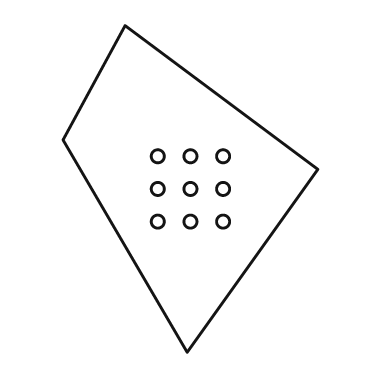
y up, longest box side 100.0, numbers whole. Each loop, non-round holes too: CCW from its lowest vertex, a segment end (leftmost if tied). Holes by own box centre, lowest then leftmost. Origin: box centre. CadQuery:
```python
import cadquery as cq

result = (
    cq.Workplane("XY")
    .moveTo(-1.0, -50.0)
    .lineTo(39.0, 6.0)
    .lineTo(-20.0, 50.0)
    .lineTo(-39.0, 15.0)
    .close()
    .moveTo(-10.0, -10.0)
    .circle(2.0)
    .moveTo(0.0, -10.0)
    .circle(2.0)
    .moveTo(10.0, -10.0)
    .circle(2.0)
    .moveTo(-10.0, 0.0)
    .circle(2.0)
    .moveTo(0.0, 0.0)
    .circle(2.0)
    .moveTo(10.0, 0.0)
    .circle(2.0)
    .moveTo(-10.0, 10.0)
    .circle(2.0)
    .moveTo(0.0, 10.0)
    .circle(2.0)
    .moveTo(10.0, 10.0)
    .circle(2.0)
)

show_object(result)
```